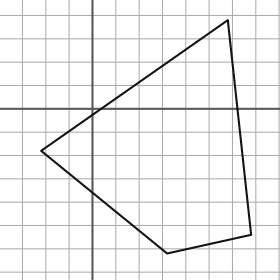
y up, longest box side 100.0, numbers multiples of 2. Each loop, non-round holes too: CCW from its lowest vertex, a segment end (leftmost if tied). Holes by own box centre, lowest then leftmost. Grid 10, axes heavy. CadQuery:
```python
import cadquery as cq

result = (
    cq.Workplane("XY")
    .moveTo(32.0, -62.0)
    .lineTo(68.0, -54.0)
    .lineTo(58.0, 38.0)
    .lineTo(-22.0, -18.0)
    .close()
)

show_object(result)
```